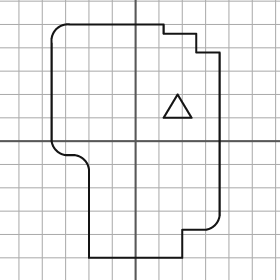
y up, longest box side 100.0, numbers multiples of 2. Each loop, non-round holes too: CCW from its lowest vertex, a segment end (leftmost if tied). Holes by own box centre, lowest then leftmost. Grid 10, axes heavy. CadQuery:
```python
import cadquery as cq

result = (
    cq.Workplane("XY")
    .moveTo(-20.0, -50.0)
    .lineTo(20.0, -50.0)
    .lineTo(20.0, -38.0)
    .lineTo(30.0, -38.0)
    .threePointArc((34.0, -36.0), (36.0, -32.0))
    .lineTo(36.0, 38.0)
    .lineTo(26.0, 38.0)
    .lineTo(26.0, 46.0)
    .lineTo(12.0, 46.0)
    .lineTo(12.0, 50.0)
    .lineTo(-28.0, 50.0)
    .threePointArc((-34.0, 48.0), (-36.0, 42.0))
    .lineTo(-36.0, 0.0)
    .threePointArc((-34.0, -4.0), (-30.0, -6.0))
    .lineTo(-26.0, -6.0)
    .threePointArc((-22.0, -8.0), (-20.0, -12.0))
    .close()
    .moveTo(12.0, 10.0)
    .lineTo(24.0, 10.0)
    .lineTo(18.0, 20.0)
    .close()
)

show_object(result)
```